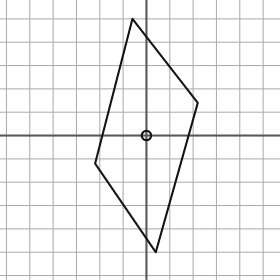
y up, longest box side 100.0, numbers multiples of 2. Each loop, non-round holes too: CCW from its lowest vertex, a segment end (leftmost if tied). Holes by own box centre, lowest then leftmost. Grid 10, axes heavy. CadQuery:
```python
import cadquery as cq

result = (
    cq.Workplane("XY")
    .moveTo(4.0, -50.0)
    .lineTo(22.0, 14.0)
    .lineTo(-6.0, 50.0)
    .lineTo(-22.0, -12.0)
    .close()
    .moveTo(0.0, 0.0)
    .circle(2.0)
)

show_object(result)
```